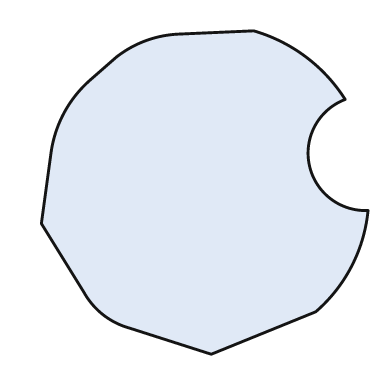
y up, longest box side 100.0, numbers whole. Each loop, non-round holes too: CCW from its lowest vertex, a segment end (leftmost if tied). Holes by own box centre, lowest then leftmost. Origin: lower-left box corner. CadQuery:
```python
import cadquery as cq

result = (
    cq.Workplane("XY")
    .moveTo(52.0, 0.0)
    .lineTo(84.0, 13.0)
    .threePointArc((95.0, 27.0), (100.0, 44.0))
    .threePointArc((82.0, 58.0), (93.0, 78.0))
    .threePointArc((81.0, 91.0), (65.0, 99.0))
    .lineTo(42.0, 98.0)
    .threePointArc((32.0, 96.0), (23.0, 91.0))
    .lineTo(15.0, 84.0)
    .threePointArc((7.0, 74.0), (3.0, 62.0))
    .lineTo(0.0, 40.0)
    .lineTo(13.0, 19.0)
    .threePointArc((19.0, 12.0), (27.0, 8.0))
    .close()
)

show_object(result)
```